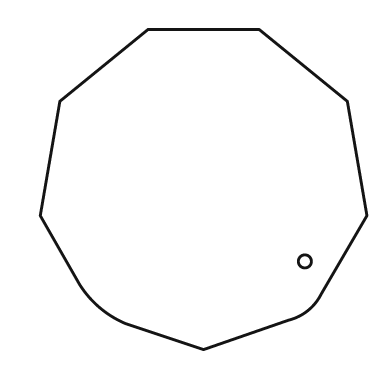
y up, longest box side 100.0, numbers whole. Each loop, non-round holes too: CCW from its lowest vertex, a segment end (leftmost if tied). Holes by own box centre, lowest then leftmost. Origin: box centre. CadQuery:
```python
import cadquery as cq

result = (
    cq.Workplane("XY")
    .moveTo(0.0, -49.0)
    .lineTo(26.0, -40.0)
    .threePointArc((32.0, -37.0), (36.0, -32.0))
    .lineTo(50.0, -8.0)
    .lineTo(44.0, 27.0)
    .lineTo(17.0, 49.0)
    .lineTo(-17.0, 49.0)
    .lineTo(-44.0, 27.0)
    .lineTo(-50.0, -8.0)
    .lineTo(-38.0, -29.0)
    .threePointArc((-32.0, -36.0), (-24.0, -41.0))
    .close()
    .moveTo(31.0, -22.0)
    .circle(2.0)
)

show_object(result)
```